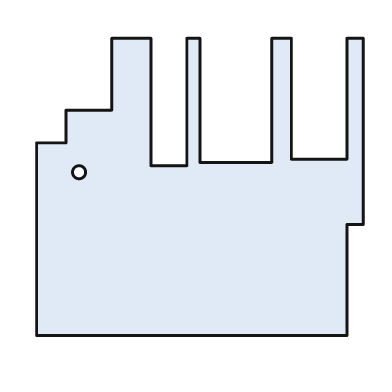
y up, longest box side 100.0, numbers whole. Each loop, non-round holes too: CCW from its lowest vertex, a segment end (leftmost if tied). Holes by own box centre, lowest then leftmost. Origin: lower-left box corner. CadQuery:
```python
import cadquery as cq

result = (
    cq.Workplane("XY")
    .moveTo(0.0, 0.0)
    .lineTo(95.0, 0.0)
    .lineTo(95.0, 34.0)
    .lineTo(100.0, 34.0)
    .lineTo(100.0, 91.0)
    .lineTo(95.0, 91.0)
    .lineTo(95.0, 54.0)
    .lineTo(78.0, 54.0)
    .lineTo(78.0, 91.0)
    .lineTo(72.0, 91.0)
    .lineTo(72.0, 53.0)
    .lineTo(50.0, 53.0)
    .lineTo(50.0, 91.0)
    .lineTo(46.0, 91.0)
    .lineTo(46.0, 52.0)
    .lineTo(35.0, 52.0)
    .lineTo(35.0, 91.0)
    .lineTo(23.0, 91.0)
    .lineTo(23.0, 69.0)
    .lineTo(9.0, 69.0)
    .lineTo(9.0, 59.0)
    .lineTo(0.0, 59.0)
    .close()
    .moveTo(13.0, 50.0)
    .circle(2.0)
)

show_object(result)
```